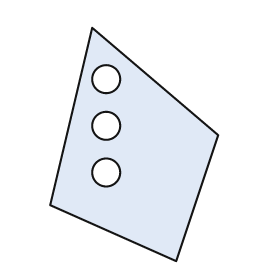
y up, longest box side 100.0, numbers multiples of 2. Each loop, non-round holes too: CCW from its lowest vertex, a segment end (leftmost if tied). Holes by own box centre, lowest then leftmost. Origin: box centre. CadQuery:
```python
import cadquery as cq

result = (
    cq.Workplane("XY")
    .moveTo(18.0, -50.0)
    .lineTo(36.0, 4.0)
    .lineTo(-18.0, 50.0)
    .lineTo(-36.0, -26.0)
    .close()
    .moveTo(-12.0, -12.0)
    .circle(6.0)
    .moveTo(-12.0, 8.0)
    .circle(6.0)
    .moveTo(-12.0, 28.0)
    .circle(6.0)
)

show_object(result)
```